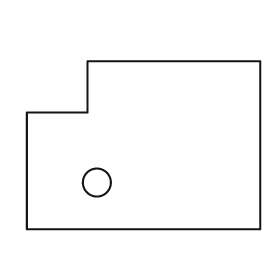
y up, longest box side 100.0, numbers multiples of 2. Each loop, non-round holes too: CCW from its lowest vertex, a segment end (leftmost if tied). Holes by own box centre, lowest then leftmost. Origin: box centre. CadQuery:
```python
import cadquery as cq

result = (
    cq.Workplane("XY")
    .moveTo(-50.0, -36.0)
    .lineTo(50.0, -36.0)
    .lineTo(50.0, 36.0)
    .lineTo(-24.0, 36.0)
    .lineTo(-24.0, 14.0)
    .lineTo(-50.0, 14.0)
    .close()
    .moveTo(-20.0, -16.0)
    .circle(6.0)
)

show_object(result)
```